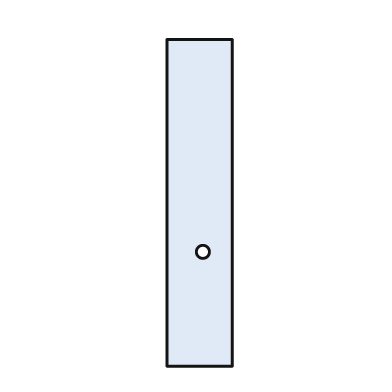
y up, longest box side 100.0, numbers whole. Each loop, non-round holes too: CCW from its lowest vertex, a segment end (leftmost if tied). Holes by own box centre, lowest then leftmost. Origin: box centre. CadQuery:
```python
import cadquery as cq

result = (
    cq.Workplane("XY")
    .moveTo(-10.0, -50.0)
    .lineTo(10.0, -50.0)
    .lineTo(10.0, 50.0)
    .lineTo(-10.0, 50.0)
    .close()
    .moveTo(1.0, -15.0)
    .circle(2.0)
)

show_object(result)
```